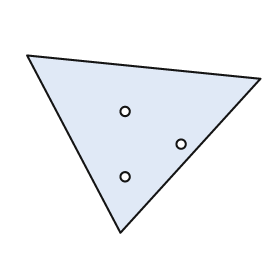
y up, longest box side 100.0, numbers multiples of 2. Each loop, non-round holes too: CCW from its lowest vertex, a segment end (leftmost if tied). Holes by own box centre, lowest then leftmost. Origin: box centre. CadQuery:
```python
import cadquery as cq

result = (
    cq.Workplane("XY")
    .moveTo(-10.0, -38.0)
    .lineTo(50.0, 28.0)
    .lineTo(-50.0, 38.0)
    .close()
    .moveTo(-8.0, -14.0)
    .circle(2.0)
    .moveTo(16.0, 0.0)
    .circle(2.0)
    .moveTo(-8.0, 14.0)
    .circle(2.0)
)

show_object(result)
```